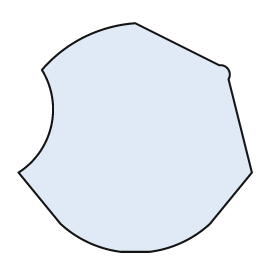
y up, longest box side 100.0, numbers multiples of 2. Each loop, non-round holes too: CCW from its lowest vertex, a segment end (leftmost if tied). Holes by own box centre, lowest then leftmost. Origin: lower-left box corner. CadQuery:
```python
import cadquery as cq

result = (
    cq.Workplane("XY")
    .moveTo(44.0, 0.0)
    .lineTo(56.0, 0.0)
    .threePointArc((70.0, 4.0), (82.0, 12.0))
    .lineTo(100.0, 34.0)
    .lineTo(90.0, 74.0)
    .threePointArc((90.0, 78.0), (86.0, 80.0))
    .lineTo(50.0, 98.0)
    .threePointArc((28.0, 92.0), (10.0, 78.0))
    .threePointArc((14.0, 54.0), (0.0, 34.0))
    .lineTo(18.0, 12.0)
    .threePointArc((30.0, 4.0), (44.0, 0.0))
    .close()
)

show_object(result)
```